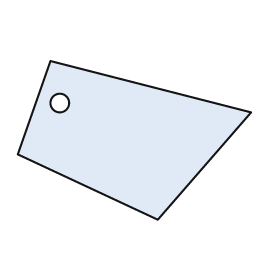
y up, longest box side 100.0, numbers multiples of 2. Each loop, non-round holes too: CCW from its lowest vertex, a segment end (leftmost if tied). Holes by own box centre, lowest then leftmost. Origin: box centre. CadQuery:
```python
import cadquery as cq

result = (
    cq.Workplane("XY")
    .moveTo(10.0, -34.0)
    .lineTo(50.0, 12.0)
    .lineTo(-36.0, 34.0)
    .lineTo(-50.0, -6.0)
    .close()
    .moveTo(-32.0, 16.0)
    .circle(4.0)
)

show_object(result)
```